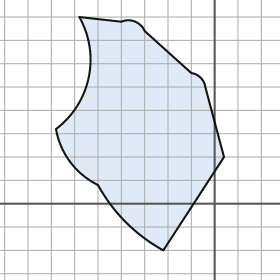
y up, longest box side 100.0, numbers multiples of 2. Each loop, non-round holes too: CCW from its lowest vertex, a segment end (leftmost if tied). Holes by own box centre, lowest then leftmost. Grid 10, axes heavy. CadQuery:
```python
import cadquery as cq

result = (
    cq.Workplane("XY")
    .moveTo(-22.0, -20.0)
    .lineTo(4.0, 20.0)
    .lineTo(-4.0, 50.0)
    .threePointArc((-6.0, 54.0), (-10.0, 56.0))
    .lineTo(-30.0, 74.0)
    .threePointArc((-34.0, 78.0), (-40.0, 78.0))
    .lineTo(-58.0, 80.0)
    .threePointArc((-54.0, 54.0), (-68.0, 32.0))
    .threePointArc((-62.0, 18.0), (-50.0, 8.0))
    .threePointArc((-38.0, -8.0), (-22.0, -20.0))
    .close()
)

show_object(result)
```